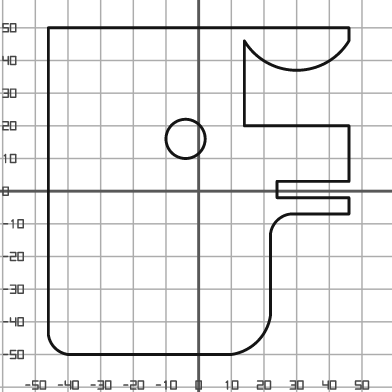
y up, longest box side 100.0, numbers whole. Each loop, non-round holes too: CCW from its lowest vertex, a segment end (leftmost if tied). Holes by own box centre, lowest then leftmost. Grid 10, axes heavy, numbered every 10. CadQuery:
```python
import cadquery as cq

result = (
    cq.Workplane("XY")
    .moveTo(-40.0, -50.0)
    .lineTo(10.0, -50.0)
    .threePointArc((18.0, -46.0), (22.0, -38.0))
    .lineTo(22.0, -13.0)
    .threePointArc((24.0, -9.0), (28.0, -7.0))
    .lineTo(46.0, -7.0)
    .lineTo(46.0, -2.0)
    .lineTo(24.0, -2.0)
    .lineTo(24.0, 3.0)
    .lineTo(46.0, 3.0)
    .lineTo(46.0, 20.0)
    .lineTo(14.0, 20.0)
    .lineTo(14.0, 46.0)
    .threePointArc((30.0, 37.0), (46.0, 46.0))
    .lineTo(46.0, 50.0)
    .lineTo(-46.0, 50.0)
    .lineTo(-46.0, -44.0)
    .threePointArc((-44.0, -48.0), (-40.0, -50.0))
    .close()
    .moveTo(-4.0, 16.0)
    .circle(6.0)
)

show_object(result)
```